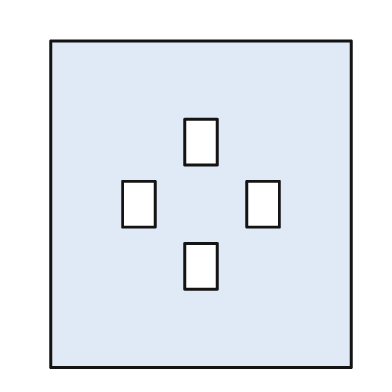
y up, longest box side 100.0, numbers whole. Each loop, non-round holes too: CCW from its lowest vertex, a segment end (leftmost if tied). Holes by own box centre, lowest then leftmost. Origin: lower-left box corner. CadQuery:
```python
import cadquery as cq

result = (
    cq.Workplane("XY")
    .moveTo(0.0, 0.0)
    .lineTo(92.0, 0.0)
    .lineTo(92.0, 100.0)
    .lineTo(0.0, 100.0)
    .close()
    .moveTo(41.0, 24.0)
    .lineTo(51.0, 24.0)
    .lineTo(51.0, 38.0)
    .lineTo(41.0, 38.0)
    .close()
    .moveTo(22.0, 43.0)
    .lineTo(32.0, 43.0)
    .lineTo(32.0, 57.0)
    .lineTo(22.0, 57.0)
    .close()
    .moveTo(60.0, 43.0)
    .lineTo(70.0, 43.0)
    .lineTo(70.0, 57.0)
    .lineTo(60.0, 57.0)
    .close()
    .moveTo(41.0, 62.0)
    .lineTo(51.0, 62.0)
    .lineTo(51.0, 76.0)
    .lineTo(41.0, 76.0)
    .close()
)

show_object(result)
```